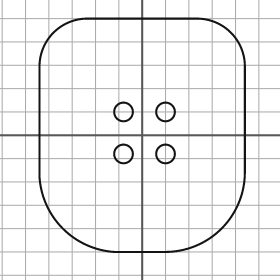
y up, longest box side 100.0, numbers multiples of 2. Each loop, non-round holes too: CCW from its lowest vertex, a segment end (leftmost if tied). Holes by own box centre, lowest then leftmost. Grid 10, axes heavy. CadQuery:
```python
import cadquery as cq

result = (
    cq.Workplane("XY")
    .moveTo(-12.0, -50.0)
    .lineTo(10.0, -50.0)
    .threePointArc((34.0, -40.0), (44.0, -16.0))
    .lineTo(44.0, 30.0)
    .threePointArc((38.0, 44.0), (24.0, 50.0))
    .lineTo(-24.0, 50.0)
    .threePointArc((-38.0, 44.0), (-44.0, 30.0))
    .lineTo(-44.0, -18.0)
    .threePointArc((-34.0, -40.0), (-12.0, -50.0))
    .close()
    .moveTo(-8.0, -8.0)
    .circle(4.0)
    .moveTo(10.0, -8.0)
    .circle(4.0)
    .moveTo(-8.0, 10.0)
    .circle(4.0)
    .moveTo(10.0, 10.0)
    .circle(4.0)
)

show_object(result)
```